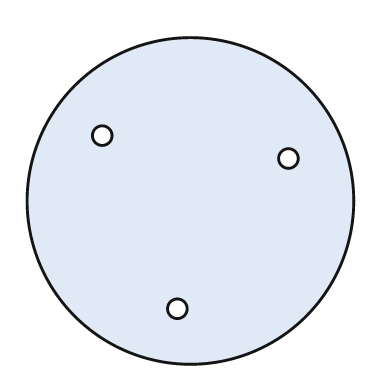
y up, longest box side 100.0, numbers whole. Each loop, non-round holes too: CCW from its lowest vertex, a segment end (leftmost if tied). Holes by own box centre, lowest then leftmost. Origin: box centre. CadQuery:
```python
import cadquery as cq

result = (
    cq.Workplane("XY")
    .moveTo(0.0, 0.0)
    .circle(50.0)
    .moveTo(-4.0, -33.0)
    .circle(3.0)
    .moveTo(30.0, 13.0)
    .circle(3.0)
    .moveTo(-27.0, 20.0)
    .circle(3.0)
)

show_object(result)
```